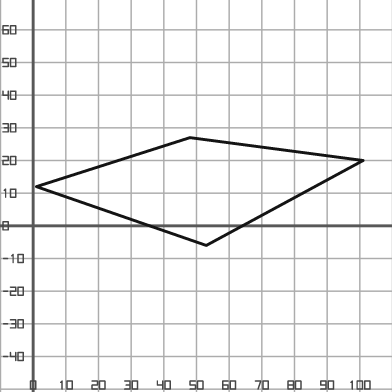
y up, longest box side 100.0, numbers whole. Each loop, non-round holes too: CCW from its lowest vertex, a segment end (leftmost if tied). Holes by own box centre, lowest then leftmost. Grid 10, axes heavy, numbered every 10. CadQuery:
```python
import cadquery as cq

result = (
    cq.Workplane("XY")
    .moveTo(53.0, -6.0)
    .lineTo(101.0, 20.0)
    .lineTo(48.0, 27.0)
    .lineTo(1.0, 12.0)
    .close()
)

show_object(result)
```